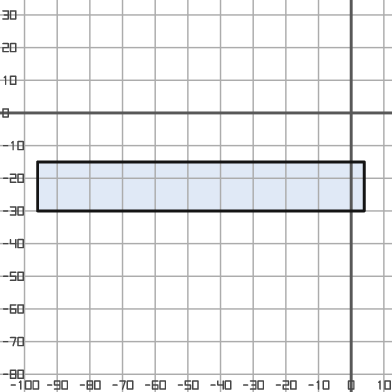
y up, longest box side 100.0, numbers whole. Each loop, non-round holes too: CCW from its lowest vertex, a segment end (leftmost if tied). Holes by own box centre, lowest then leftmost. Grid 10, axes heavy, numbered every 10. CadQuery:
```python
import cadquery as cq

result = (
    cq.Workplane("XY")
    .moveTo(-96.0, -30.0)
    .lineTo(4.0, -30.0)
    .lineTo(4.0, -15.0)
    .lineTo(-96.0, -15.0)
    .close()
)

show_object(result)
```